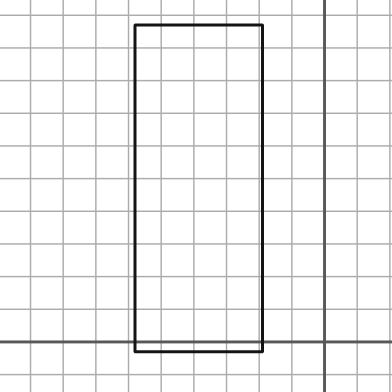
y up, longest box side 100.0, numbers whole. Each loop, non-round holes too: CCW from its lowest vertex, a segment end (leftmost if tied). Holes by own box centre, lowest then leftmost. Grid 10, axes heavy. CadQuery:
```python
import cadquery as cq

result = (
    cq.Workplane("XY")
    .moveTo(-58.0, -3.0)
    .lineTo(-19.0, -3.0)
    .lineTo(-19.0, 97.0)
    .lineTo(-58.0, 97.0)
    .close()
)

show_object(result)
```